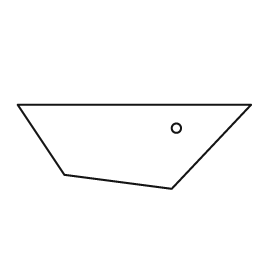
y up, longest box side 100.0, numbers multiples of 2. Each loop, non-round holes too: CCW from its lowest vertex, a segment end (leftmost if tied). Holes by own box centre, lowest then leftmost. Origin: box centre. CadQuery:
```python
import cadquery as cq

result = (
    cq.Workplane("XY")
    .moveTo(16.0, -18.0)
    .lineTo(50.0, 18.0)
    .lineTo(-50.0, 18.0)
    .lineTo(-30.0, -12.0)
    .close()
    .moveTo(18.0, 8.0)
    .circle(2.0)
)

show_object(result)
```